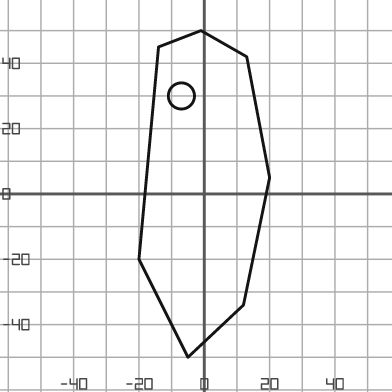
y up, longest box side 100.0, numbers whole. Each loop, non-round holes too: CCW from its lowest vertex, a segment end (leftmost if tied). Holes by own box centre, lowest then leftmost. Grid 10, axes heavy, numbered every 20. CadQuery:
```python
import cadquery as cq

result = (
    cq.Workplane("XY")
    .moveTo(-5.0, -50.0)
    .lineTo(12.0, -34.0)
    .lineTo(20.0, 5.0)
    .lineTo(13.0, 42.0)
    .lineTo(-1.0, 50.0)
    .lineTo(-14.0, 45.0)
    .lineTo(-20.0, -20.0)
    .close()
    .moveTo(-7.0, 30.0)
    .circle(4.0)
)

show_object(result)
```